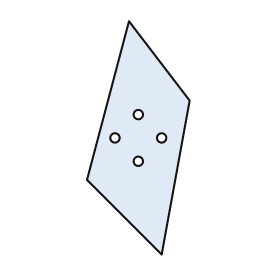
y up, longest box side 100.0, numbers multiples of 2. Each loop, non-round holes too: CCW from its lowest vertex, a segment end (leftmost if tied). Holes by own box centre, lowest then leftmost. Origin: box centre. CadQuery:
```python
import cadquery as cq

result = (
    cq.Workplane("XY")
    .moveTo(10.0, -50.0)
    .lineTo(22.0, 16.0)
    .lineTo(-4.0, 50.0)
    .lineTo(-22.0, -18.0)
    .close()
    .moveTo(0.0, -10.0)
    .circle(2.0)
    .moveTo(-10.0, 0.0)
    .circle(2.0)
    .moveTo(10.0, 0.0)
    .circle(2.0)
    .moveTo(0.0, 10.0)
    .circle(2.0)
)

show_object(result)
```